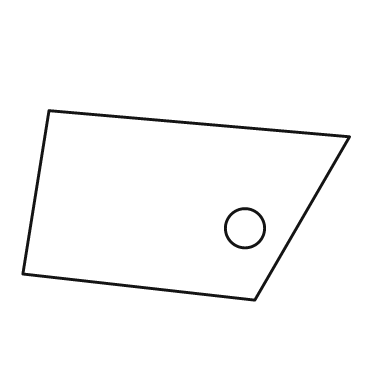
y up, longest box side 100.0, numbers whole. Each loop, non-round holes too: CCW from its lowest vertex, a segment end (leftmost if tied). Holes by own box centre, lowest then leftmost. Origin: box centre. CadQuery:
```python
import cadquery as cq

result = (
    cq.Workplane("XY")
    .moveTo(21.0, -29.0)
    .lineTo(50.0, 21.0)
    .lineTo(-42.0, 29.0)
    .lineTo(-50.0, -21.0)
    .close()
    .moveTo(18.0, -7.0)
    .circle(6.0)
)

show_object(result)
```